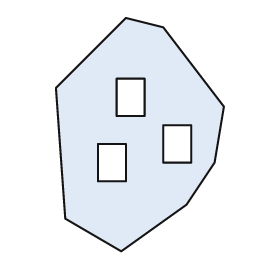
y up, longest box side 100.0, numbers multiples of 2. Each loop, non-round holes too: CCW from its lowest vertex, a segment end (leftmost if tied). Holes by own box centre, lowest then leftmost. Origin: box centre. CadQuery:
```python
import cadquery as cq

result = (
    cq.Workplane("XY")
    .moveTo(-8.0, -50.0)
    .lineTo(20.0, -30.0)
    .lineTo(32.0, -12.0)
    .lineTo(36.0, 12.0)
    .lineTo(10.0, 46.0)
    .lineTo(-6.0, 50.0)
    .lineTo(-36.0, 20.0)
    .lineTo(-32.0, -36.0)
    .close()
    .moveTo(-18.0, -20.0)
    .lineTo(-6.0, -20.0)
    .lineTo(-6.0, -4.0)
    .lineTo(-18.0, -4.0)
    .close()
    .moveTo(10.0, -12.0)
    .lineTo(22.0, -12.0)
    .lineTo(22.0, 4.0)
    .lineTo(10.0, 4.0)
    .close()
    .moveTo(-10.0, 8.0)
    .lineTo(2.0, 8.0)
    .lineTo(2.0, 24.0)
    .lineTo(-10.0, 24.0)
    .close()
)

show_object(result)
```